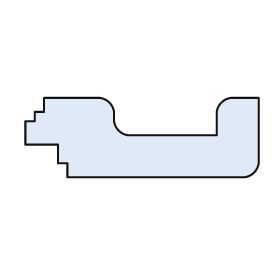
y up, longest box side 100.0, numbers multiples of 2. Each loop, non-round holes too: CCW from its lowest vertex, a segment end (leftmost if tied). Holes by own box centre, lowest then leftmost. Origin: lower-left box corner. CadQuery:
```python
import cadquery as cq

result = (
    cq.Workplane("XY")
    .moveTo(18.0, 0.0)
    .lineTo(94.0, 0.0)
    .threePointArc((98.0, 2.0), (100.0, 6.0))
    .lineTo(100.0, 34.0)
    .lineTo(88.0, 34.0)
    .threePointArc((84.0, 32.0), (82.0, 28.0))
    .lineTo(82.0, 18.0)
    .lineTo(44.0, 18.0)
    .threePointArc((40.0, 20.0), (38.0, 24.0))
    .lineTo(38.0, 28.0)
    .threePointArc((36.0, 32.0), (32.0, 34.0))
    .lineTo(8.0, 34.0)
    .lineTo(8.0, 28.0)
    .lineTo(4.0, 28.0)
    .lineTo(4.0, 24.0)
    .lineTo(0.0, 24.0)
    .lineTo(0.0, 14.0)
    .lineTo(14.0, 14.0)
    .lineTo(14.0, 6.0)
    .lineTo(18.0, 6.0)
    .close()
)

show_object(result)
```